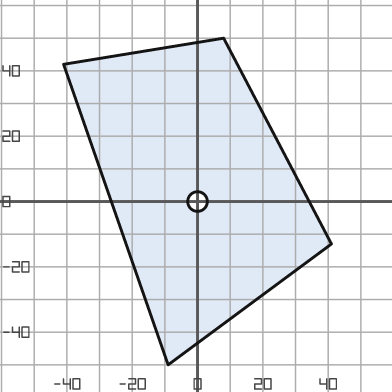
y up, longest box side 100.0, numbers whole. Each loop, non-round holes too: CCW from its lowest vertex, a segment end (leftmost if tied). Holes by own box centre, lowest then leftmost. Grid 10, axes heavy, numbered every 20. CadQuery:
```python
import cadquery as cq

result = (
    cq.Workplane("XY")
    .moveTo(-9.0, -50.0)
    .lineTo(41.0, -13.0)
    .lineTo(8.0, 50.0)
    .lineTo(-41.0, 42.0)
    .close()
    .moveTo(0.0, 0.0)
    .circle(3.0)
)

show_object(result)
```